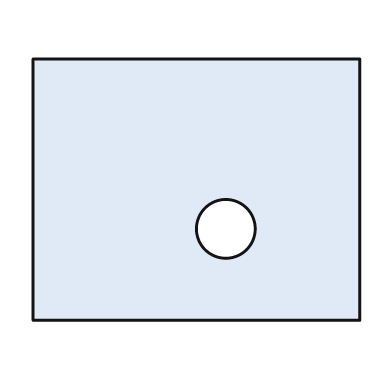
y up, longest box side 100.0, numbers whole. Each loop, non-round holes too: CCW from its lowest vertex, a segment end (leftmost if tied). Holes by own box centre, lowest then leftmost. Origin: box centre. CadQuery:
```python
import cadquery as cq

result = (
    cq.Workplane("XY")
    .moveTo(-50.0, -40.0)
    .lineTo(50.0, -40.0)
    .lineTo(50.0, 40.0)
    .lineTo(-50.0, 40.0)
    .close()
    .moveTo(9.0, -12.0)
    .circle(9.0)
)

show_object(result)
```